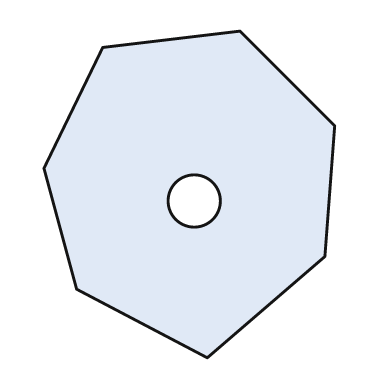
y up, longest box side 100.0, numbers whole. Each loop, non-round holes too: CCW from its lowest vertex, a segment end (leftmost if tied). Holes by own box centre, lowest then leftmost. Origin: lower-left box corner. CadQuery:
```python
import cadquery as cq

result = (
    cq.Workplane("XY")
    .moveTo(50.0, 0.0)
    .lineTo(86.0, 31.0)
    .lineTo(89.0, 71.0)
    .lineTo(60.0, 100.0)
    .lineTo(18.0, 95.0)
    .lineTo(0.0, 58.0)
    .lineTo(10.0, 21.0)
    .close()
    .moveTo(46.0, 48.0)
    .circle(8.0)
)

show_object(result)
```